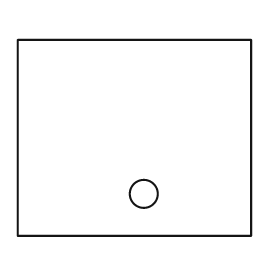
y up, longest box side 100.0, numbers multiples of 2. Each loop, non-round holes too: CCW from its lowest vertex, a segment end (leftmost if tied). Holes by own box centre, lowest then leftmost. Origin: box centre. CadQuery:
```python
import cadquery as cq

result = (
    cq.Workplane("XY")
    .moveTo(-50.0, -42.0)
    .lineTo(50.0, -42.0)
    .lineTo(50.0, 42.0)
    .lineTo(-50.0, 42.0)
    .close()
    .moveTo(4.0, -24.0)
    .circle(6.0)
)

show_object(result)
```